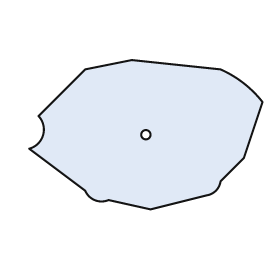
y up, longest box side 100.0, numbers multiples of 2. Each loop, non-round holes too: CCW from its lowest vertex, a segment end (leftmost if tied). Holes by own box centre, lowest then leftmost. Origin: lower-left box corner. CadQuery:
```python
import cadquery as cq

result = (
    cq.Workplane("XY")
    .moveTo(52.0, 0.0)
    .lineTo(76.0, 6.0)
    .threePointArc((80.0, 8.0), (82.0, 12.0))
    .lineTo(92.0, 22.0)
    .lineTo(100.0, 46.0)
    .threePointArc((92.0, 54.0), (82.0, 60.0))
    .lineTo(44.0, 64.0)
    .lineTo(24.0, 60.0)
    .lineTo(4.0, 40.0)
    .threePointArc((6.0, 32.0), (0.0, 26.0))
    .lineTo(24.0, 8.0)
    .threePointArc((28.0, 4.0), (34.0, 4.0))
    .close()
    .moveTo(50.0, 32.0)
    .circle(2.0)
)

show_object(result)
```